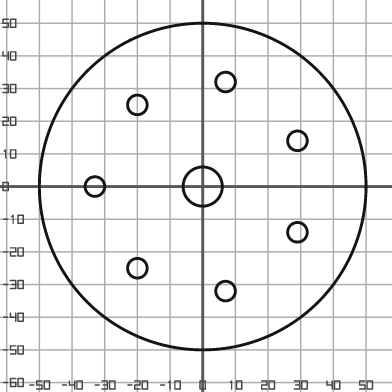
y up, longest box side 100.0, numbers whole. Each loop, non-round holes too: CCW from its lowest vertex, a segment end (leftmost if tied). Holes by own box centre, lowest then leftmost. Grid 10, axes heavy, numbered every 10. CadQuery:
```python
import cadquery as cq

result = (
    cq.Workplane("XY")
    .moveTo(0.0, 0.0)
    .circle(50.0)
    .moveTo(7.0, -32.0)
    .circle(3.0)
    .moveTo(-20.0, -25.0)
    .circle(3.0)
    .moveTo(29.0, -14.0)
    .circle(3.0)
    .moveTo(-33.0, 0.0)
    .circle(3.0)
    .moveTo(0.0, 0.0)
    .circle(6.0)
    .moveTo(29.0, 14.0)
    .circle(3.0)
    .moveTo(-20.0, 25.0)
    .circle(3.0)
    .moveTo(7.0, 32.0)
    .circle(3.0)
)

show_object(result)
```